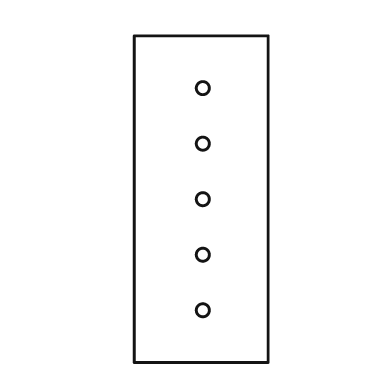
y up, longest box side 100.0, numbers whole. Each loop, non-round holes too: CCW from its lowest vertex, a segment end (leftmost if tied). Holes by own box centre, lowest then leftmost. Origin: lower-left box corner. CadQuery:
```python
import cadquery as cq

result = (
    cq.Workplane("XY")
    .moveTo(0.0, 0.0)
    .lineTo(41.0, 0.0)
    .lineTo(41.0, 100.0)
    .lineTo(0.0, 100.0)
    .close()
    .moveTo(21.0, 16.0)
    .circle(2.0)
    .moveTo(21.0, 33.0)
    .circle(2.0)
    .moveTo(21.0, 50.0)
    .circle(2.0)
    .moveTo(21.0, 67.0)
    .circle(2.0)
    .moveTo(21.0, 84.0)
    .circle(2.0)
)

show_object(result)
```